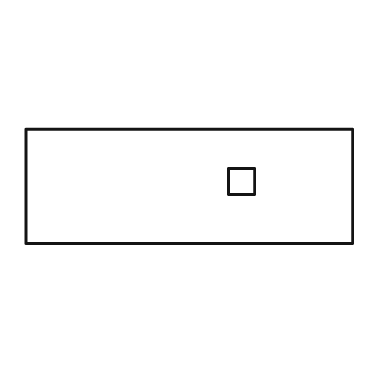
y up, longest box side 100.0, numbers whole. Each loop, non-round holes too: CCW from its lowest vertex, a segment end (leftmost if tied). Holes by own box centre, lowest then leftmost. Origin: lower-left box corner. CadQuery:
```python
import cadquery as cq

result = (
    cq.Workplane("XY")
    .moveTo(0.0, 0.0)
    .lineTo(100.0, 0.0)
    .lineTo(100.0, 35.0)
    .lineTo(0.0, 35.0)
    .close()
    .moveTo(62.0, 15.0)
    .lineTo(70.0, 15.0)
    .lineTo(70.0, 23.0)
    .lineTo(62.0, 23.0)
    .close()
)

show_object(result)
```